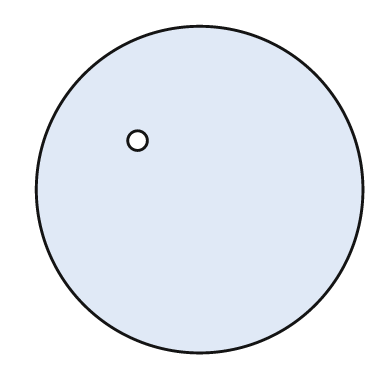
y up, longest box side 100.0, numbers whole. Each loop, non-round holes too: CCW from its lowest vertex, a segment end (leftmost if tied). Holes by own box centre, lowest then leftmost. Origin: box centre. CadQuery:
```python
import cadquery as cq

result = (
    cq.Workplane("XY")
    .moveTo(0.0, 0.0)
    .circle(50.0)
    .moveTo(-19.0, 15.0)
    .circle(3.0)
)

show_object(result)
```